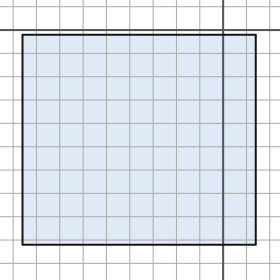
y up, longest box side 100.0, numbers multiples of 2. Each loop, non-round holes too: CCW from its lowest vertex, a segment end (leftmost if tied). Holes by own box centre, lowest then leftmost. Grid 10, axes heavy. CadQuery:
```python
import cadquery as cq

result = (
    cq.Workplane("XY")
    .moveTo(-86.0, -92.0)
    .lineTo(14.0, -92.0)
    .lineTo(14.0, -2.0)
    .lineTo(-86.0, -2.0)
    .close()
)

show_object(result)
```